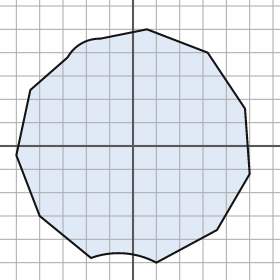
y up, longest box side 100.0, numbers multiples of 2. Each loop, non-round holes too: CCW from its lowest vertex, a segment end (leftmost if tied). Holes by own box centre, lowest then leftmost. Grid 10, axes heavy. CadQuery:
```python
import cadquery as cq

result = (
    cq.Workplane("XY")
    .moveTo(10.0, -50.0)
    .lineTo(36.0, -36.0)
    .lineTo(50.0, -12.0)
    .lineTo(48.0, 16.0)
    .lineTo(32.0, 40.0)
    .lineTo(6.0, 50.0)
    .lineTo(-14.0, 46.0)
    .threePointArc((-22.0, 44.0), (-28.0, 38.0))
    .lineTo(-44.0, 24.0)
    .lineTo(-50.0, -4.0)
    .lineTo(-40.0, -30.0)
    .lineTo(-18.0, -48.0)
    .threePointArc((-4.0, -46.0), (10.0, -50.0))
    .close()
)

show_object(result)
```